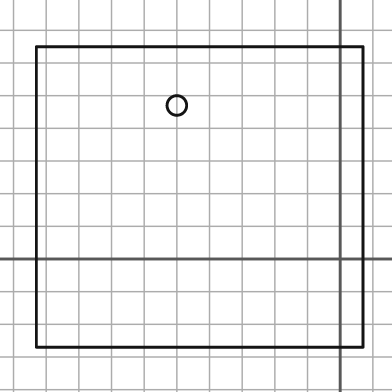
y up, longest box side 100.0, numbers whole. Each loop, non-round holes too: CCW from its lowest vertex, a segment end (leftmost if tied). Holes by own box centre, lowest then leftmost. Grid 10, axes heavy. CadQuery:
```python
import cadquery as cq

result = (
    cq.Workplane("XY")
    .moveTo(-93.0, -27.0)
    .lineTo(7.0, -27.0)
    .lineTo(7.0, 65.0)
    .lineTo(-93.0, 65.0)
    .close()
    .moveTo(-50.0, 47.0)
    .circle(3.0)
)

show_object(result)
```